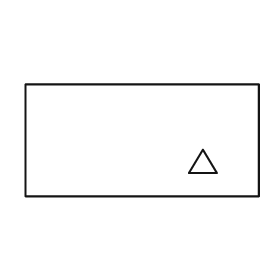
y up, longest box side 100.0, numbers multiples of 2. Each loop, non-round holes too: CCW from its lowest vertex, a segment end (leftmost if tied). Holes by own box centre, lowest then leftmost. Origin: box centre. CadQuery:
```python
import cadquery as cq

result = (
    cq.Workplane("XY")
    .moveTo(-50.0, -24.0)
    .lineTo(50.0, -24.0)
    .lineTo(50.0, 24.0)
    .lineTo(-50.0, 24.0)
    .close()
    .moveTo(20.0, -14.0)
    .lineTo(32.0, -14.0)
    .lineTo(26.0, -4.0)
    .close()
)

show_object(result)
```